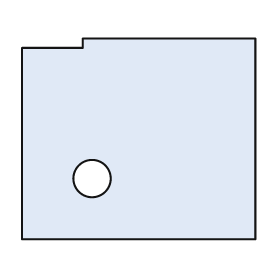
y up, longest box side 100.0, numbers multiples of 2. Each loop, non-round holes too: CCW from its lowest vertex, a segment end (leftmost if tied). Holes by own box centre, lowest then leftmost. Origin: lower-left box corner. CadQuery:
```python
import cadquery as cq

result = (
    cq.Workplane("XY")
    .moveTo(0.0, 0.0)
    .lineTo(100.0, 0.0)
    .lineTo(100.0, 86.0)
    .lineTo(26.0, 86.0)
    .lineTo(26.0, 82.0)
    .lineTo(0.0, 82.0)
    .close()
    .moveTo(30.0, 26.0)
    .circle(8.0)
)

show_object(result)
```